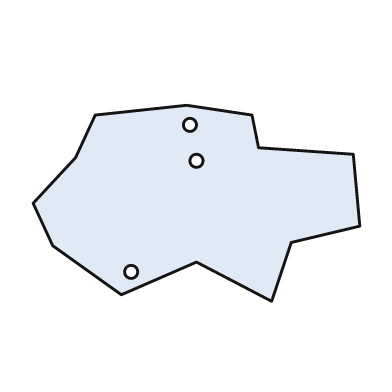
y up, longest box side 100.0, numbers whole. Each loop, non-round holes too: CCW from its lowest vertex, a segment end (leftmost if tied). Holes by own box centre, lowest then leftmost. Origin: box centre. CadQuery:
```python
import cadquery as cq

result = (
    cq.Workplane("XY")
    .moveTo(23.0, -30.0)
    .lineTo(29.0, -12.0)
    .lineTo(50.0, -7.0)
    .lineTo(48.0, 15.0)
    .lineTo(19.0, 17.0)
    .lineTo(17.0, 27.0)
    .lineTo(-3.0, 30.0)
    .lineTo(-31.0, 27.0)
    .lineTo(-37.0, 14.0)
    .lineTo(-50.0, 0.0)
    .lineTo(-44.0, -13.0)
    .lineTo(-23.0, -28.0)
    .lineTo(0.0, -18.0)
    .close()
    .moveTo(-20.0, -21.0)
    .circle(2.0)
    .moveTo(0.0, 13.0)
    .circle(2.0)
    .moveTo(-2.0, 24.0)
    .circle(2.0)
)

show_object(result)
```